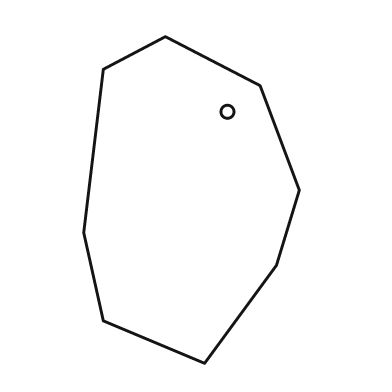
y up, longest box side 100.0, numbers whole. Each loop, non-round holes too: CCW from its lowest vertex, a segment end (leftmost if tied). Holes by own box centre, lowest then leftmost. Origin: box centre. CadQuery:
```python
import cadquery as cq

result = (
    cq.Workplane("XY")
    .moveTo(4.0, -50.0)
    .lineTo(26.0, -20.0)
    .lineTo(33.0, 3.0)
    .lineTo(21.0, 35.0)
    .lineTo(-8.0, 50.0)
    .lineTo(-27.0, 40.0)
    .lineTo(-33.0, -10.0)
    .lineTo(-27.0, -37.0)
    .close()
    .moveTo(11.0, 27.0)
    .circle(2.0)
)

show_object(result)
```